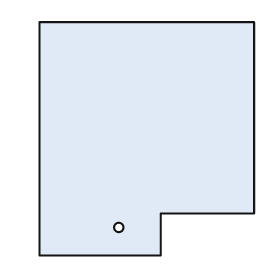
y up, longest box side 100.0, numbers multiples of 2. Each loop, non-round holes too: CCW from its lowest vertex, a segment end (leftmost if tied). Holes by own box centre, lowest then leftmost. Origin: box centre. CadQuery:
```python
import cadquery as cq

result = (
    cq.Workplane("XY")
    .moveTo(-46.0, -50.0)
    .lineTo(6.0, -50.0)
    .lineTo(6.0, -32.0)
    .lineTo(46.0, -32.0)
    .lineTo(46.0, 50.0)
    .lineTo(-46.0, 50.0)
    .close()
    .moveTo(-12.0, -38.0)
    .circle(2.0)
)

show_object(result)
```